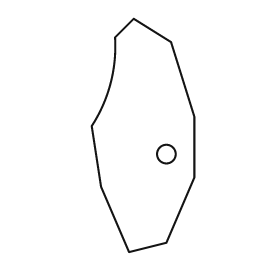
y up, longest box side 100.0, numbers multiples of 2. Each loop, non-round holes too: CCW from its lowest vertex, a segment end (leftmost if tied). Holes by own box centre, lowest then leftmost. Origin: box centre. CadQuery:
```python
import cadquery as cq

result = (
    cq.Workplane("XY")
    .moveTo(-6.0, -50.0)
    .lineTo(10.0, -46.0)
    .lineTo(22.0, -18.0)
    .lineTo(22.0, 8.0)
    .lineTo(12.0, 40.0)
    .lineTo(-4.0, 50.0)
    .lineTo(-12.0, 42.0)
    .threePointArc((-14.0, 22.0), (-22.0, 4.0))
    .lineTo(-18.0, -22.0)
    .close()
    .moveTo(10.0, -8.0)
    .circle(4.0)
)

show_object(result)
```